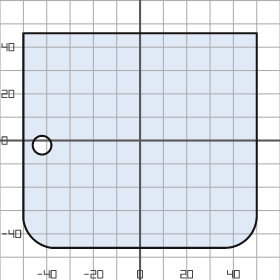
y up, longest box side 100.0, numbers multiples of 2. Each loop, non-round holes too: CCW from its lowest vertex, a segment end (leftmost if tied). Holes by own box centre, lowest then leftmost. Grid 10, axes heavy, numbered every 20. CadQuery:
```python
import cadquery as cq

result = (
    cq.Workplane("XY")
    .moveTo(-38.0, -46.0)
    .lineTo(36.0, -46.0)
    .threePointArc((46.0, -42.0), (50.0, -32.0))
    .lineTo(50.0, 46.0)
    .lineTo(-50.0, 46.0)
    .lineTo(-50.0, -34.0)
    .threePointArc((-46.0, -42.0), (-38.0, -46.0))
    .close()
    .moveTo(-42.0, -2.0)
    .circle(4.0)
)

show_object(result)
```